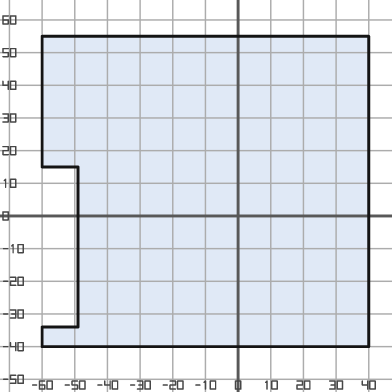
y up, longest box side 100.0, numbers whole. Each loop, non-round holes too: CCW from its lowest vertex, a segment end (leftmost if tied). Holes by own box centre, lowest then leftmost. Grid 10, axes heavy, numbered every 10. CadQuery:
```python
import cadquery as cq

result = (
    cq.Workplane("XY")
    .moveTo(-60.0, -40.0)
    .lineTo(40.0, -40.0)
    .lineTo(40.0, 55.0)
    .lineTo(-60.0, 55.0)
    .lineTo(-60.0, 15.0)
    .lineTo(-49.0, 15.0)
    .lineTo(-49.0, -34.0)
    .lineTo(-60.0, -34.0)
    .close()
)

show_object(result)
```